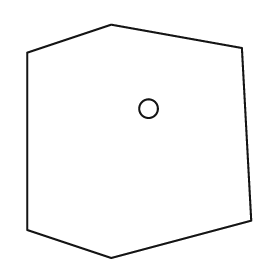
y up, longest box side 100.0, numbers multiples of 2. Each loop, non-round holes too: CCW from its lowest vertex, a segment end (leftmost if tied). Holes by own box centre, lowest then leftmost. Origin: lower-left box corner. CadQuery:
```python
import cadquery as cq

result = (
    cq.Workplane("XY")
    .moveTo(36.0, 0.0)
    .lineTo(96.0, 16.0)
    .lineTo(92.0, 90.0)
    .lineTo(36.0, 100.0)
    .lineTo(0.0, 88.0)
    .lineTo(0.0, 12.0)
    .close()
    .moveTo(52.0, 64.0)
    .circle(4.0)
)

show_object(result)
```